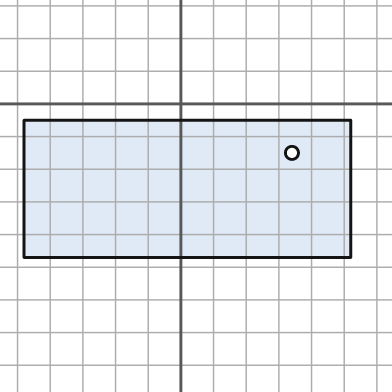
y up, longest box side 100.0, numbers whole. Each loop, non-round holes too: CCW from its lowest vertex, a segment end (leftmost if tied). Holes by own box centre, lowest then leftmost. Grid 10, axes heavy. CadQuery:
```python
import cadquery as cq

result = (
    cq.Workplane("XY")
    .moveTo(-48.0, -47.0)
    .lineTo(52.0, -47.0)
    .lineTo(52.0, -5.0)
    .lineTo(-48.0, -5.0)
    .close()
    .moveTo(34.0, -15.0)
    .circle(2.0)
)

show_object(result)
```